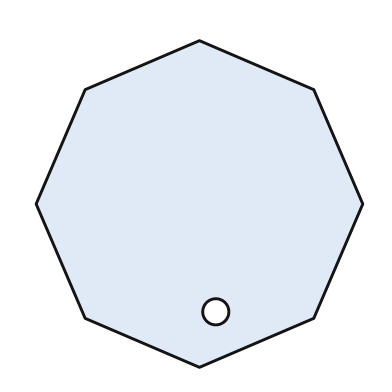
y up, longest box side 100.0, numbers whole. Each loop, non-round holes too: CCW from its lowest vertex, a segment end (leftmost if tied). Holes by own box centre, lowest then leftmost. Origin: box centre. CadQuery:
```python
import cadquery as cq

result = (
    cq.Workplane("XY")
    .moveTo(0.0, -50.0)
    .lineTo(35.0, -35.0)
    .lineTo(50.0, 0.0)
    .lineTo(35.0, 35.0)
    .lineTo(0.0, 50.0)
    .lineTo(-35.0, 35.0)
    .lineTo(-50.0, 0.0)
    .lineTo(-35.0, -35.0)
    .close()
    .moveTo(5.0, -33.0)
    .circle(4.0)
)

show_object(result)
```